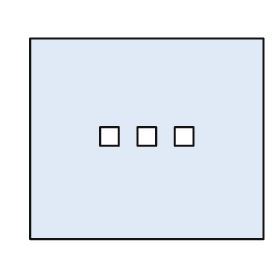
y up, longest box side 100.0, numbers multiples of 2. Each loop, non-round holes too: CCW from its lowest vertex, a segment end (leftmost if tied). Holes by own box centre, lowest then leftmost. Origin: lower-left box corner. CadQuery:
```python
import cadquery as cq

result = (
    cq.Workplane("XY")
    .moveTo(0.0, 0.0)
    .lineTo(100.0, 0.0)
    .lineTo(100.0, 86.0)
    .lineTo(0.0, 86.0)
    .close()
    .moveTo(30.0, 40.0)
    .lineTo(38.0, 40.0)
    .lineTo(38.0, 48.0)
    .lineTo(30.0, 48.0)
    .close()
    .moveTo(46.0, 40.0)
    .lineTo(54.0, 40.0)
    .lineTo(54.0, 48.0)
    .lineTo(46.0, 48.0)
    .close()
    .moveTo(62.0, 40.0)
    .lineTo(70.0, 40.0)
    .lineTo(70.0, 48.0)
    .lineTo(62.0, 48.0)
    .close()
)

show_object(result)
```